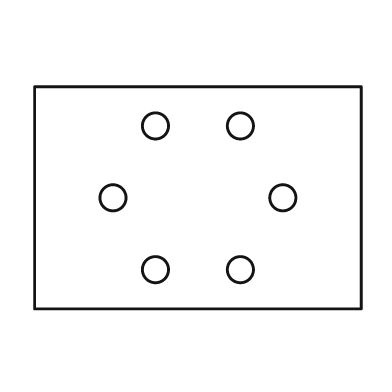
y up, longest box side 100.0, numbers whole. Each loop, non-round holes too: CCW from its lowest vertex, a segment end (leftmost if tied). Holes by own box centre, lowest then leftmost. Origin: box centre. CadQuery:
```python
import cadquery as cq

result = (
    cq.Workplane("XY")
    .moveTo(-50.0, -34.0)
    .lineTo(50.0, -34.0)
    .lineTo(50.0, 34.0)
    .lineTo(-50.0, 34.0)
    .close()
    .moveTo(-13.0, -22.0)
    .circle(4.0)
    .moveTo(13.0, -22.0)
    .circle(4.0)
    .moveTo(-26.0, 0.0)
    .circle(4.0)
    .moveTo(26.0, 0.0)
    .circle(4.0)
    .moveTo(-13.0, 22.0)
    .circle(4.0)
    .moveTo(13.0, 22.0)
    .circle(4.0)
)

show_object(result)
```